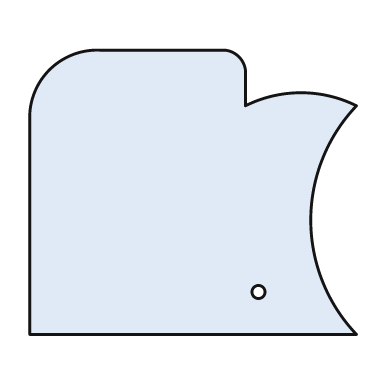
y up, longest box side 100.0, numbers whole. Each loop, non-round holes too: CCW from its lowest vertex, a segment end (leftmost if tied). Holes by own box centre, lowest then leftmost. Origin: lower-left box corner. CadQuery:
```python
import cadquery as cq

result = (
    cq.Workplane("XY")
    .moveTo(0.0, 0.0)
    .lineTo(100.0, 0.0)
    .threePointArc((86.0, 35.0), (100.0, 70.0))
    .threePointArc((83.0, 74.0), (66.0, 70.0))
    .lineTo(66.0, 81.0)
    .threePointArc((64.0, 85.0), (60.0, 87.0))
    .lineTo(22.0, 87.0)
    .threePointArc((6.0, 81.0), (0.0, 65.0))
    .close()
    .moveTo(70.0, 13.0)
    .circle(2.0)
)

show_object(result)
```